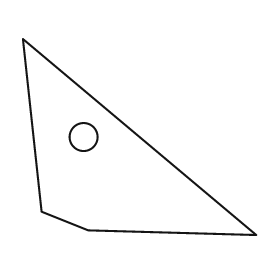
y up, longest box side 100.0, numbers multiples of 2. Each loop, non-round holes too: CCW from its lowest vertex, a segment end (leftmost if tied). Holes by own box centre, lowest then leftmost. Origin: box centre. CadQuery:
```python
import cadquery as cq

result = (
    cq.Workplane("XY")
    .moveTo(50.0, -42.0)
    .lineTo(-50.0, 42.0)
    .lineTo(-42.0, -32.0)
    .lineTo(-22.0, -40.0)
    .close()
    .moveTo(-24.0, 0.0)
    .circle(6.0)
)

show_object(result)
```